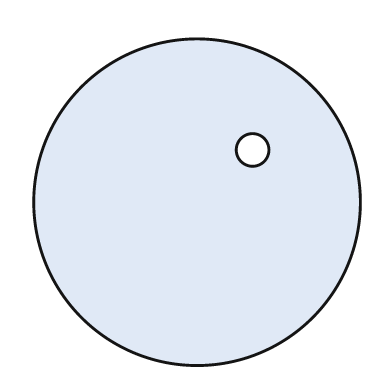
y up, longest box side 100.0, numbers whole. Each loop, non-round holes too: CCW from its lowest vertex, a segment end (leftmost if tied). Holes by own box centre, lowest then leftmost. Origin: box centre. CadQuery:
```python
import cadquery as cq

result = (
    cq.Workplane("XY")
    .moveTo(0.0, 0.0)
    .circle(50.0)
    .moveTo(17.0, 16.0)
    .circle(5.0)
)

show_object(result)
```